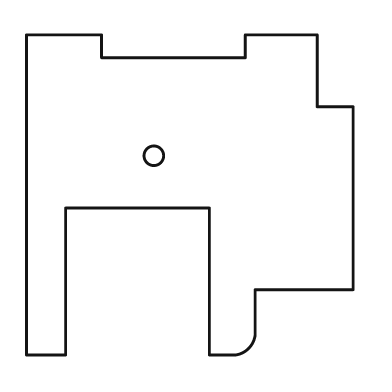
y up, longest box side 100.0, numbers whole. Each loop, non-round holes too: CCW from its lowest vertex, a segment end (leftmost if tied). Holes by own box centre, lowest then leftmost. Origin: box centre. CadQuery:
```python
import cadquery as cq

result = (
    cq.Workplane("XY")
    .moveTo(-50.0, -49.0)
    .lineTo(-38.0, -49.0)
    .lineTo(-38.0, -4.0)
    .lineTo(6.0, -4.0)
    .lineTo(6.0, -49.0)
    .lineTo(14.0, -49.0)
    .threePointArc((18.0, -47.0), (20.0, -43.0))
    .lineTo(20.0, -29.0)
    .lineTo(50.0, -29.0)
    .lineTo(50.0, 27.0)
    .lineTo(39.0, 27.0)
    .lineTo(39.0, 49.0)
    .lineTo(17.0, 49.0)
    .lineTo(17.0, 42.0)
    .lineTo(-27.0, 42.0)
    .lineTo(-27.0, 49.0)
    .lineTo(-50.0, 49.0)
    .close()
    .moveTo(-11.0, 12.0)
    .circle(3.0)
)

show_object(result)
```